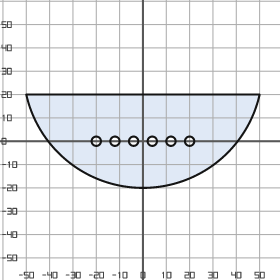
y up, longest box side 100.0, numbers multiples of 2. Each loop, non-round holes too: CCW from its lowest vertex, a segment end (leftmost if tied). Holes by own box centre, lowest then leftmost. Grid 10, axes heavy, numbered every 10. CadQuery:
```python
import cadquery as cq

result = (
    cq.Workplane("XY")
    .moveTo(-50.0, 20.0)
    .threePointArc((0.0, -20.0), (50.0, 20.0))
    .close()
    .moveTo(-20.0, 0.0)
    .circle(2.0)
    .moveTo(-12.0, 0.0)
    .circle(2.0)
    .moveTo(-4.0, 0.0)
    .circle(2.0)
    .moveTo(4.0, 0.0)
    .circle(2.0)
    .moveTo(12.0, 0.0)
    .circle(2.0)
    .moveTo(20.0, 0.0)
    .circle(2.0)
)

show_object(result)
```